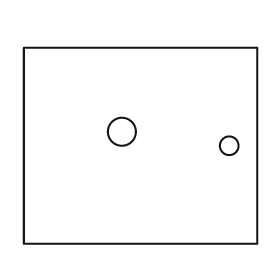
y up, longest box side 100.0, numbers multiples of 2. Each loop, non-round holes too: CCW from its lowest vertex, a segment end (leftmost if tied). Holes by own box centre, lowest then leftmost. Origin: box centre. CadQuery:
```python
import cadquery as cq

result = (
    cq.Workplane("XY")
    .moveTo(-50.0, -42.0)
    .lineTo(50.0, -42.0)
    .lineTo(50.0, 42.0)
    .lineTo(-50.0, 42.0)
    .close()
    .moveTo(38.0, 0.0)
    .circle(4.0)
    .moveTo(-8.0, 6.0)
    .circle(6.0)
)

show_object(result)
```